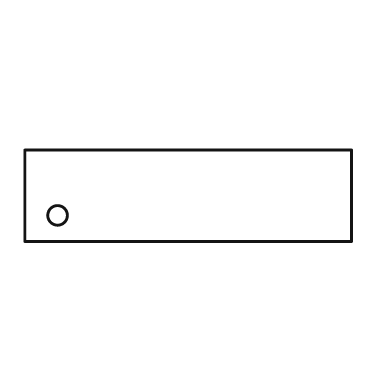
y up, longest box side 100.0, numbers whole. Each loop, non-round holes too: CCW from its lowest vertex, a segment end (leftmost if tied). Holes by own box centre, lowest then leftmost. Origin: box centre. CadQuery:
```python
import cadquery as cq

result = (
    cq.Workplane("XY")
    .moveTo(-50.0, -14.0)
    .lineTo(50.0, -14.0)
    .lineTo(50.0, 14.0)
    .lineTo(-50.0, 14.0)
    .close()
    .moveTo(-40.0, -6.0)
    .circle(3.0)
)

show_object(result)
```